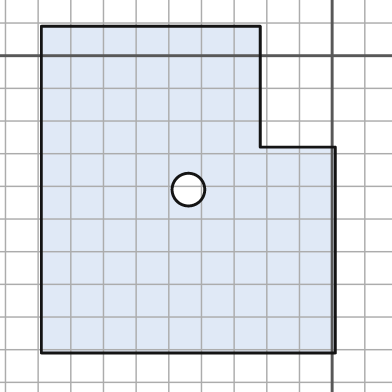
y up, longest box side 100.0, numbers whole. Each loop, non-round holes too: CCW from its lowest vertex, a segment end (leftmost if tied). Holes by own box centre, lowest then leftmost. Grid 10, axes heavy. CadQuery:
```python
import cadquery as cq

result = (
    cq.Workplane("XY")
    .moveTo(-89.0, -91.0)
    .lineTo(1.0, -91.0)
    .lineTo(1.0, -28.0)
    .lineTo(-22.0, -28.0)
    .lineTo(-22.0, 9.0)
    .lineTo(-89.0, 9.0)
    .close()
    .moveTo(-44.0, -41.0)
    .circle(5.0)
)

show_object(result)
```